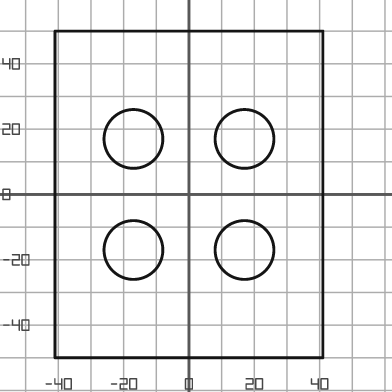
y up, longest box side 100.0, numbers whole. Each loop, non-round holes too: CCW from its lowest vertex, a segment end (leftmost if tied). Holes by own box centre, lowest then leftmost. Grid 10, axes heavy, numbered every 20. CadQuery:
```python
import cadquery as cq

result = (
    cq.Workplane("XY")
    .moveTo(-41.0, -50.0)
    .lineTo(41.0, -50.0)
    .lineTo(41.0, 50.0)
    .lineTo(-41.0, 50.0)
    .close()
    .moveTo(-17.0, -17.0)
    .circle(9.0)
    .moveTo(17.0, -17.0)
    .circle(9.0)
    .moveTo(-17.0, 17.0)
    .circle(9.0)
    .moveTo(17.0, 17.0)
    .circle(9.0)
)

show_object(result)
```